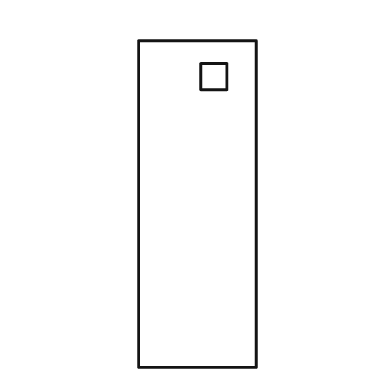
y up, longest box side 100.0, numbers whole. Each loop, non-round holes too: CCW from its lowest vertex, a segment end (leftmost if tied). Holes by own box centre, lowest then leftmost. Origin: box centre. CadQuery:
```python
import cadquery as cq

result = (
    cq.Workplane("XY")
    .moveTo(-18.0, -50.0)
    .lineTo(18.0, -50.0)
    .lineTo(18.0, 50.0)
    .lineTo(-18.0, 50.0)
    .close()
    .moveTo(1.0, 35.0)
    .lineTo(9.0, 35.0)
    .lineTo(9.0, 43.0)
    .lineTo(1.0, 43.0)
    .close()
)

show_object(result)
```